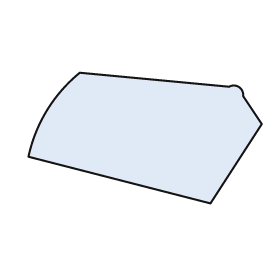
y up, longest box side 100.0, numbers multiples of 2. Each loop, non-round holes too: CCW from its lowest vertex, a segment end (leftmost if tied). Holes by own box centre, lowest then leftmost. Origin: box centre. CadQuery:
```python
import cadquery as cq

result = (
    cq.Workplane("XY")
    .moveTo(28.0, -28.0)
    .lineTo(50.0, 6.0)
    .lineTo(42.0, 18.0)
    .threePointArc((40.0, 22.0), (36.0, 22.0))
    .lineTo(-28.0, 28.0)
    .threePointArc((-42.0, 12.0), (-50.0, -8.0))
    .close()
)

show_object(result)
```